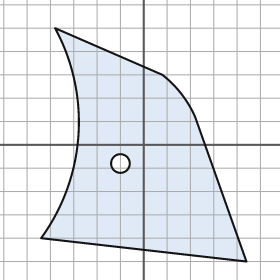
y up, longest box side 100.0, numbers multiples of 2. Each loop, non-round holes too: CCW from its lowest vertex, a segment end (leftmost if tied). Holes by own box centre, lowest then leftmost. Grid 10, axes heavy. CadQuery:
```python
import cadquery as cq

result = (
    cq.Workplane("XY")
    .moveTo(44.0, -50.0)
    .lineTo(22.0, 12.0)
    .threePointArc((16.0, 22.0), (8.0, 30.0))
    .lineTo(-38.0, 50.0)
    .threePointArc((-28.0, 4.0), (-44.0, -40.0))
    .close()
    .moveTo(-10.0, -8.0)
    .circle(4.0)
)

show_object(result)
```